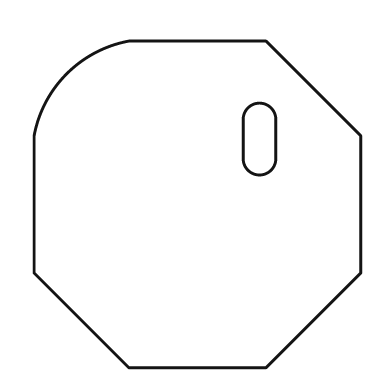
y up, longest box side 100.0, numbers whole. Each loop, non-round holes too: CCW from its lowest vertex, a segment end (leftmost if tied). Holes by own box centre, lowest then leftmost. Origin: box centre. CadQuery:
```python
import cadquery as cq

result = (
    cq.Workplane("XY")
    .moveTo(-21.0, -50.0)
    .lineTo(21.0, -50.0)
    .lineTo(50.0, -21.0)
    .lineTo(50.0, 21.0)
    .lineTo(21.0, 50.0)
    .lineTo(-21.0, 50.0)
    .threePointArc((-40.0, 40.0), (-50.0, 21.0))
    .lineTo(-50.0, -21.0)
    .close()
    .moveTo(14.0, 14.0)
    .threePointArc((19.0, 9.0), (24.0, 14.0))
    .lineTo(24.0, 26.0)
    .threePointArc((19.0, 31.0), (14.0, 26.0))
    .close()
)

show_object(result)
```